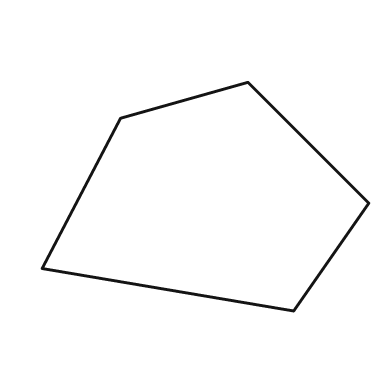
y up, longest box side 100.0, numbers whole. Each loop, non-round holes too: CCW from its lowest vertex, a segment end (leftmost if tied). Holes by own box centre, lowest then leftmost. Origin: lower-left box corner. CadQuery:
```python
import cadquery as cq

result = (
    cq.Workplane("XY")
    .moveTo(77.0, 0.0)
    .lineTo(100.0, 33.0)
    .lineTo(63.0, 70.0)
    .lineTo(24.0, 59.0)
    .lineTo(0.0, 13.0)
    .close()
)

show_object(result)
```